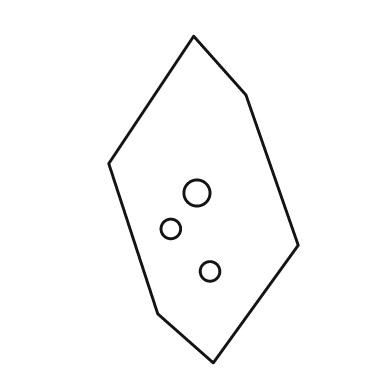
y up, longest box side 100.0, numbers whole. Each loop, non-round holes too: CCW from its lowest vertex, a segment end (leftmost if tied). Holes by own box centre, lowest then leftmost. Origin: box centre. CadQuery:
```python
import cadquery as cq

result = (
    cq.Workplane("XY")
    .moveTo(3.0, -50.0)
    .lineTo(29.0, -14.0)
    .lineTo(13.0, 32.0)
    .lineTo(-3.0, 50.0)
    .lineTo(-29.0, 11.0)
    .lineTo(-14.0, -35.0)
    .close()
    .moveTo(2.0, -22.0)
    .circle(3.0)
    .moveTo(-10.0, -9.0)
    .circle(3.0)
    .moveTo(-2.0, 2.0)
    .circle(4.0)
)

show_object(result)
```